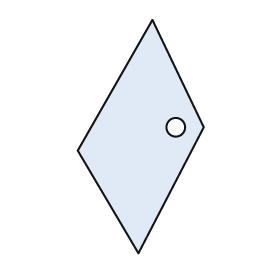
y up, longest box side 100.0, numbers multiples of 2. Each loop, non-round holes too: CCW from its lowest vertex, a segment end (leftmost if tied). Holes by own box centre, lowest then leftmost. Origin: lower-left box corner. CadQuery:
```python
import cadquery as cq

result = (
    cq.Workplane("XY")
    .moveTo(26.0, 0.0)
    .lineTo(54.0, 54.0)
    .lineTo(32.0, 100.0)
    .lineTo(0.0, 44.0)
    .close()
    .moveTo(42.0, 54.0)
    .circle(4.0)
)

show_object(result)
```